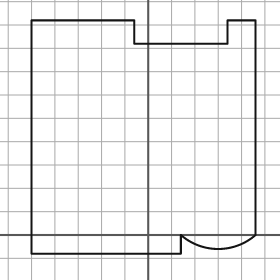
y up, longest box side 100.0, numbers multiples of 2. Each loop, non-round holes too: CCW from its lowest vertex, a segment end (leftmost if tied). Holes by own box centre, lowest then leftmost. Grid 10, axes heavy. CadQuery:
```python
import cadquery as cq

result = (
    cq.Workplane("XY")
    .moveTo(-50.0, -8.0)
    .lineTo(14.0, -8.0)
    .lineTo(14.0, 0.0)
    .threePointArc((30.0, -6.0), (46.0, 0.0))
    .lineTo(46.0, 92.0)
    .lineTo(34.0, 92.0)
    .lineTo(34.0, 82.0)
    .lineTo(-6.0, 82.0)
    .lineTo(-6.0, 92.0)
    .lineTo(-50.0, 92.0)
    .close()
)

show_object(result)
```